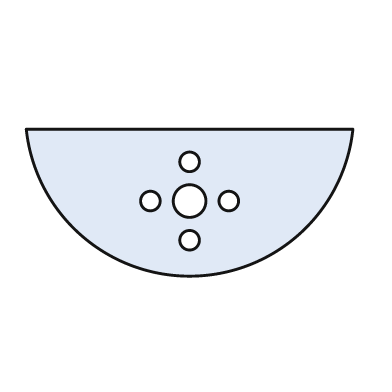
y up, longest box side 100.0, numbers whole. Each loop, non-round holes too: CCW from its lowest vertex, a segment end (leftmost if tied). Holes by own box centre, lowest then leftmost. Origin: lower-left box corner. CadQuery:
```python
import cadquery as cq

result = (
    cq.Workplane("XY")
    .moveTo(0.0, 45.0)
    .threePointArc((50.0, 0.0), (100.0, 45.0))
    .close()
    .moveTo(50.0, 11.0)
    .circle(3.0)
    .moveTo(38.0, 23.0)
    .circle(3.0)
    .moveTo(50.0, 23.0)
    .circle(5.0)
    .moveTo(62.0, 23.0)
    .circle(3.0)
    .moveTo(50.0, 35.0)
    .circle(3.0)
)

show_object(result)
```